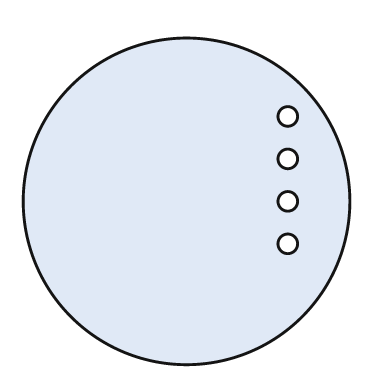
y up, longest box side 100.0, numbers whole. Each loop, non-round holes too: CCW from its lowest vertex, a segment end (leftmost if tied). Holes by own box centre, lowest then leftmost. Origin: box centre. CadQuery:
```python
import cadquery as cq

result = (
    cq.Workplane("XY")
    .moveTo(0.0, 0.0)
    .circle(50.0)
    .moveTo(31.0, -13.0)
    .circle(3.0)
    .moveTo(31.0, 0.0)
    .circle(3.0)
    .moveTo(31.0, 13.0)
    .circle(3.0)
    .moveTo(31.0, 26.0)
    .circle(3.0)
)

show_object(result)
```